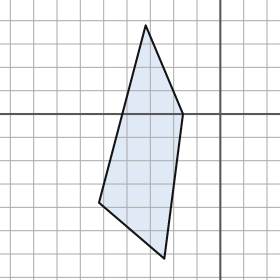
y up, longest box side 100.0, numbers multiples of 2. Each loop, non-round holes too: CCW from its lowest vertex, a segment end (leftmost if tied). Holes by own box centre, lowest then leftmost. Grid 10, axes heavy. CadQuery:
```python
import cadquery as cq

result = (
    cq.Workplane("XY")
    .moveTo(-24.0, -62.0)
    .lineTo(-16.0, 0.0)
    .lineTo(-32.0, 38.0)
    .lineTo(-52.0, -38.0)
    .close()
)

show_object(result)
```